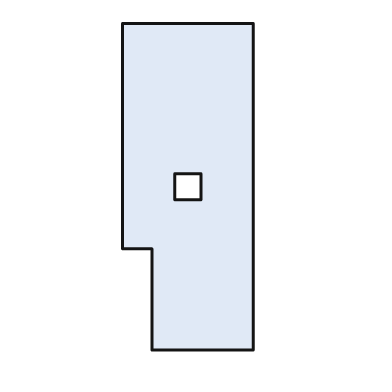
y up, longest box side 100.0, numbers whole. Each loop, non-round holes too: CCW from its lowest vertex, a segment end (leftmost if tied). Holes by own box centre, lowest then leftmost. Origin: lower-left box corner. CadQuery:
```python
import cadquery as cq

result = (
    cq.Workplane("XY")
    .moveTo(9.0, 0.0)
    .lineTo(40.0, 0.0)
    .lineTo(40.0, 100.0)
    .lineTo(0.0, 100.0)
    .lineTo(0.0, 31.0)
    .lineTo(9.0, 31.0)
    .close()
    .moveTo(16.0, 46.0)
    .lineTo(24.0, 46.0)
    .lineTo(24.0, 54.0)
    .lineTo(16.0, 54.0)
    .close()
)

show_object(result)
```